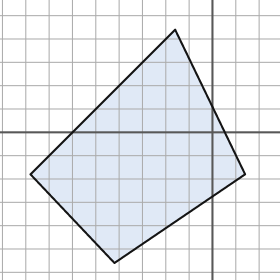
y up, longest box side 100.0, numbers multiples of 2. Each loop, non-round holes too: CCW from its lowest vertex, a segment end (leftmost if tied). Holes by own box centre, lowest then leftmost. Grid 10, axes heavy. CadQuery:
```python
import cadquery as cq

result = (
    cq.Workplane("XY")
    .moveTo(-42.0, -56.0)
    .lineTo(14.0, -18.0)
    .lineTo(-16.0, 44.0)
    .lineTo(-78.0, -18.0)
    .close()
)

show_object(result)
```